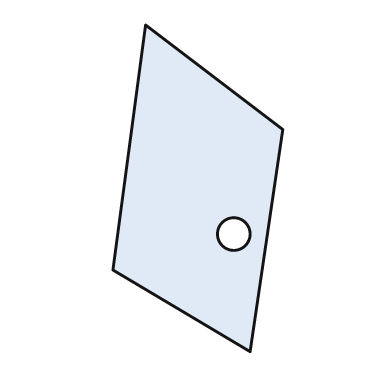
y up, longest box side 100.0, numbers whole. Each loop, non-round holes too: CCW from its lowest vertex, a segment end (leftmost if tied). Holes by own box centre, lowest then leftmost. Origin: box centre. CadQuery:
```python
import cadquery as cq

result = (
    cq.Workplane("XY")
    .moveTo(16.0, -50.0)
    .lineTo(26.0, 18.0)
    .lineTo(-16.0, 50.0)
    .lineTo(-26.0, -25.0)
    .close()
    .moveTo(11.0, -14.0)
    .circle(5.0)
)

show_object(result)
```